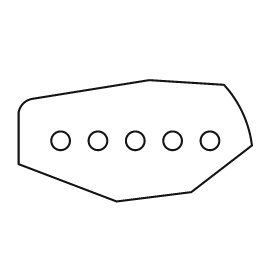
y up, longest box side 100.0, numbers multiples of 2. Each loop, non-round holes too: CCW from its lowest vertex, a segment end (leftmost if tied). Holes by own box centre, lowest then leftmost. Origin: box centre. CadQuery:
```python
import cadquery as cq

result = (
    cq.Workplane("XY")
    .moveTo(-8.0, -26.0)
    .lineTo(24.0, -22.0)
    .lineTo(50.0, -2.0)
    .threePointArc((46.0, 12.0), (38.0, 24.0))
    .lineTo(6.0, 26.0)
    .lineTo(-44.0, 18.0)
    .threePointArc((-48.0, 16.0), (-50.0, 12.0))
    .lineTo(-50.0, -10.0)
    .close()
    .moveTo(-32.0, 0.0)
    .circle(4.0)
    .moveTo(-16.0, 0.0)
    .circle(4.0)
    .moveTo(0.0, 0.0)
    .circle(4.0)
    .moveTo(16.0, 0.0)
    .circle(4.0)
    .moveTo(32.0, 0.0)
    .circle(4.0)
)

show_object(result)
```